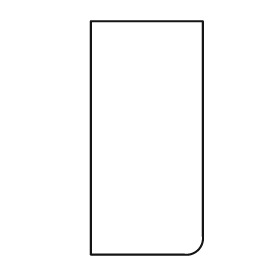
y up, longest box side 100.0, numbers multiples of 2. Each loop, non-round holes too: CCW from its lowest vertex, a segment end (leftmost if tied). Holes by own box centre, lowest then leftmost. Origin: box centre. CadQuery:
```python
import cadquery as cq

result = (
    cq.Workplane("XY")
    .moveTo(-24.0, -50.0)
    .lineTo(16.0, -50.0)
    .threePointArc((22.0, -48.0), (24.0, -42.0))
    .lineTo(24.0, 50.0)
    .lineTo(-24.0, 50.0)
    .close()
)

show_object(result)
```